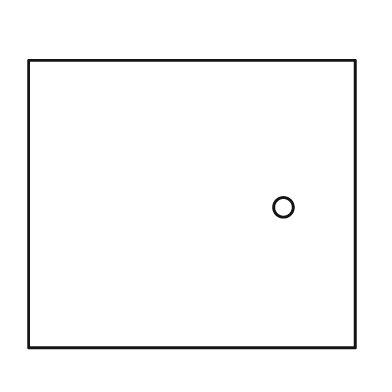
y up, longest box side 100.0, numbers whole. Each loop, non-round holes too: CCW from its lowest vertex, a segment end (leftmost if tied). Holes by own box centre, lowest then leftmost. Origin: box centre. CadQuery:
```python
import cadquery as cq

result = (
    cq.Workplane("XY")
    .moveTo(-50.0, -44.0)
    .lineTo(50.0, -44.0)
    .lineTo(50.0, 44.0)
    .lineTo(-50.0, 44.0)
    .close()
    .moveTo(28.0, -1.0)
    .circle(3.0)
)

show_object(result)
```